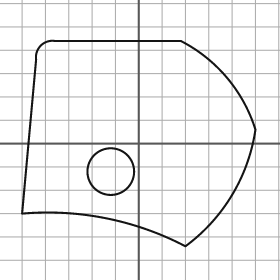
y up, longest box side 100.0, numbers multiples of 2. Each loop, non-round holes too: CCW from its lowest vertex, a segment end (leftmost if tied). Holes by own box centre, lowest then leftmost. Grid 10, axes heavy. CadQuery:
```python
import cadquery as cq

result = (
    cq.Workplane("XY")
    .moveTo(20.0, -44.0)
    .threePointArc((40.0, -22.0), (50.0, 6.0))
    .threePointArc((38.0, 28.0), (18.0, 44.0))
    .lineTo(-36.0, 44.0)
    .threePointArc((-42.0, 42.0), (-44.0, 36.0))
    .lineTo(-50.0, -30.0)
    .threePointArc((-14.0, -32.0), (20.0, -44.0))
    .close()
    .moveTo(-12.0, -12.0)
    .circle(10.0)
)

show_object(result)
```